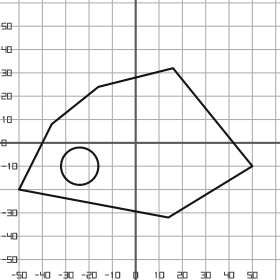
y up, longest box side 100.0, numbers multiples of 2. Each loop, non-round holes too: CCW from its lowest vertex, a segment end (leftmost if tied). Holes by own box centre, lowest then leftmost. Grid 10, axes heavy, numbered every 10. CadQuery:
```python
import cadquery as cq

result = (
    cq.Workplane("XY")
    .moveTo(14.0, -32.0)
    .lineTo(50.0, -10.0)
    .lineTo(16.0, 32.0)
    .lineTo(-16.0, 24.0)
    .lineTo(-36.0, 8.0)
    .lineTo(-50.0, -20.0)
    .close()
    .moveTo(-24.0, -10.0)
    .circle(8.0)
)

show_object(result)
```